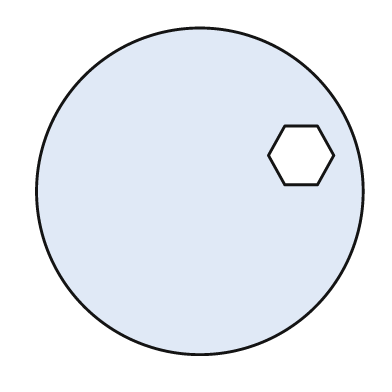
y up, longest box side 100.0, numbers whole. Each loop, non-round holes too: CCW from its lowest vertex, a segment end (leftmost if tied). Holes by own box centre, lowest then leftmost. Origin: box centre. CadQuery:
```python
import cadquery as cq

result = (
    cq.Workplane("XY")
    .moveTo(0.0, 0.0)
    .circle(50.0)
    .moveTo(26.0, 2.0)
    .lineTo(36.0, 2.0)
    .lineTo(41.0, 11.0)
    .lineTo(36.0, 20.0)
    .lineTo(26.0, 20.0)
    .lineTo(21.0, 11.0)
    .close()
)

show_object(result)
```